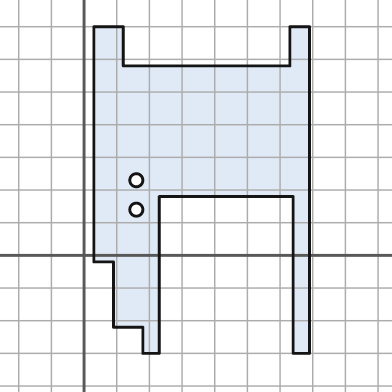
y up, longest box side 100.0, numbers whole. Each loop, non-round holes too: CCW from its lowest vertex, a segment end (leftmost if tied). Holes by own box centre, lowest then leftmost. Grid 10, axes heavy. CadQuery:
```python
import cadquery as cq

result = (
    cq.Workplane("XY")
    .moveTo(18.0, -30.0)
    .lineTo(23.0, -30.0)
    .lineTo(23.0, 18.0)
    .lineTo(64.0, 18.0)
    .lineTo(64.0, -30.0)
    .lineTo(69.0, -30.0)
    .lineTo(69.0, 70.0)
    .lineTo(63.0, 70.0)
    .lineTo(63.0, 58.0)
    .lineTo(12.0, 58.0)
    .lineTo(12.0, 70.0)
    .lineTo(3.0, 70.0)
    .lineTo(3.0, -2.0)
    .lineTo(9.0, -2.0)
    .lineTo(9.0, -22.0)
    .lineTo(18.0, -22.0)
    .close()
    .moveTo(16.0, 14.0)
    .circle(2.0)
    .moveTo(16.0, 23.0)
    .circle(2.0)
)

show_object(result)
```